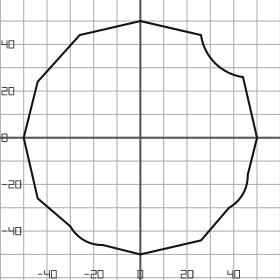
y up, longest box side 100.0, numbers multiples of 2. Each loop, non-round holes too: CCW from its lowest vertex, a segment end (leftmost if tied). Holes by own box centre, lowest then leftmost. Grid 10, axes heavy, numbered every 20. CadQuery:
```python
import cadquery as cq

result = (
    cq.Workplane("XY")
    .moveTo(0.0, -50.0)
    .lineTo(26.0, -44.0)
    .lineTo(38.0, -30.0)
    .threePointArc((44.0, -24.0), (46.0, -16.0))
    .lineTo(50.0, 0.0)
    .lineTo(44.0, 26.0)
    .threePointArc((32.0, 32.0), (26.0, 44.0))
    .lineTo(0.0, 50.0)
    .lineTo(-26.0, 44.0)
    .lineTo(-44.0, 24.0)
    .lineTo(-50.0, 0.0)
    .lineTo(-44.0, -26.0)
    .lineTo(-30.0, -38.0)
    .threePointArc((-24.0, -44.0), (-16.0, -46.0))
    .close()
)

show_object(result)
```